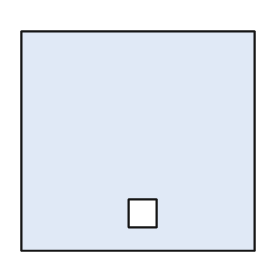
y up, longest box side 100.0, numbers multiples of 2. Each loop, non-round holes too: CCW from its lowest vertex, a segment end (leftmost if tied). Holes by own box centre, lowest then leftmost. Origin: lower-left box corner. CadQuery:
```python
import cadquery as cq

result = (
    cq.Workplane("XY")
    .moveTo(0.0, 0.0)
    .lineTo(100.0, 0.0)
    .lineTo(100.0, 94.0)
    .lineTo(0.0, 94.0)
    .close()
    .moveTo(46.0, 10.0)
    .lineTo(58.0, 10.0)
    .lineTo(58.0, 22.0)
    .lineTo(46.0, 22.0)
    .close()
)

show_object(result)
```